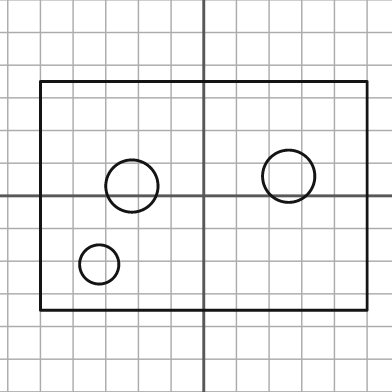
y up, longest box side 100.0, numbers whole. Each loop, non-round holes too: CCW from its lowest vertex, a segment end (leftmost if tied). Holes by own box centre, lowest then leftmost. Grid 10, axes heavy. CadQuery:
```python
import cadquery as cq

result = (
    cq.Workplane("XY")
    .moveTo(-50.0, -35.0)
    .lineTo(50.0, -35.0)
    .lineTo(50.0, 35.0)
    .lineTo(-50.0, 35.0)
    .close()
    .moveTo(-32.0, -21.0)
    .circle(6.0)
    .moveTo(-22.0, 3.0)
    .circle(8.0)
    .moveTo(26.0, 6.0)
    .circle(8.0)
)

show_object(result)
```